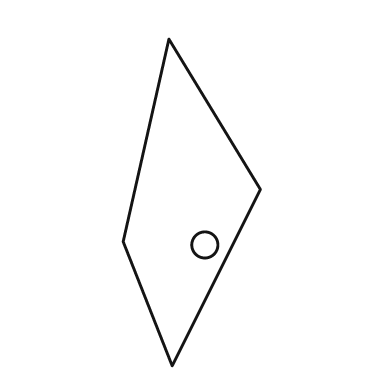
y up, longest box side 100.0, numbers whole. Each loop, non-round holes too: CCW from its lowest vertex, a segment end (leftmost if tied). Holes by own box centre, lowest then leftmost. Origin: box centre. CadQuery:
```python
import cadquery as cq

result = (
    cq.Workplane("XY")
    .moveTo(-6.0, -50.0)
    .lineTo(21.0, 4.0)
    .lineTo(-7.0, 50.0)
    .lineTo(-21.0, -12.0)
    .close()
    .moveTo(4.0, -13.0)
    .circle(4.0)
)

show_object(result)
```